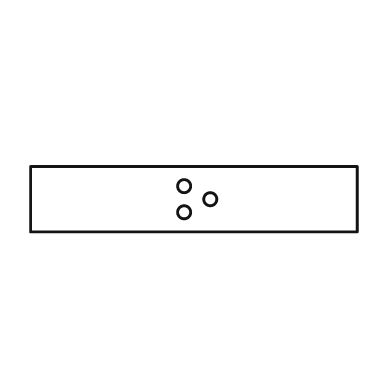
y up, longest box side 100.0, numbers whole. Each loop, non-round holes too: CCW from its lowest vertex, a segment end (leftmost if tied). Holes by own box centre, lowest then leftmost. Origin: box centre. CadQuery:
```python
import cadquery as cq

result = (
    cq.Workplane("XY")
    .moveTo(-50.0, -10.0)
    .lineTo(50.0, -10.0)
    .lineTo(50.0, 10.0)
    .lineTo(-50.0, 10.0)
    .close()
    .moveTo(-3.0, -4.0)
    .circle(2.0)
    .moveTo(5.0, 0.0)
    .circle(2.0)
    .moveTo(-3.0, 4.0)
    .circle(2.0)
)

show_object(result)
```